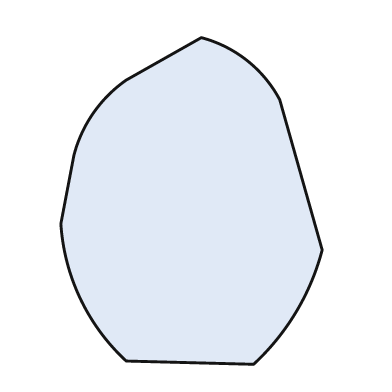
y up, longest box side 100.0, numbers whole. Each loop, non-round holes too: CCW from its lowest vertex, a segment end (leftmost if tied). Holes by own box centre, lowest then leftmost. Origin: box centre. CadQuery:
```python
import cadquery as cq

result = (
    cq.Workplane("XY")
    .moveTo(19.0, -50.0)
    .threePointArc((32.0, -34.0), (40.0, -15.0))
    .lineTo(27.0, 31.0)
    .threePointArc((17.0, 43.0), (3.0, 50.0))
    .lineTo(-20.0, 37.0)
    .threePointArc((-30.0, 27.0), (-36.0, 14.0))
    .lineTo(-40.0, -7.0)
    .threePointArc((-34.0, -30.0), (-20.0, -49.0))
    .close()
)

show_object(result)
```